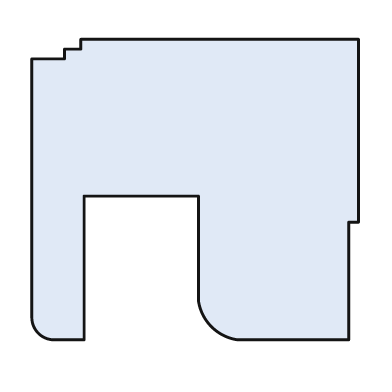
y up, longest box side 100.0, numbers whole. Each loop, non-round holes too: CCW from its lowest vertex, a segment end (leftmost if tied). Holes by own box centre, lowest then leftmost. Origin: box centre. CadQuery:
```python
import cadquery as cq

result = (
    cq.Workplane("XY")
    .moveTo(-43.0, -46.0)
    .lineTo(-34.0, -46.0)
    .lineTo(-34.0, -2.0)
    .lineTo(1.0, -2.0)
    .lineTo(1.0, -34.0)
    .threePointArc((5.0, -42.0), (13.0, -46.0))
    .lineTo(47.0, -46.0)
    .lineTo(47.0, -10.0)
    .lineTo(50.0, -10.0)
    .lineTo(50.0, 46.0)
    .lineTo(-35.0, 46.0)
    .lineTo(-35.0, 43.0)
    .lineTo(-40.0, 43.0)
    .lineTo(-40.0, 40.0)
    .lineTo(-50.0, 40.0)
    .lineTo(-50.0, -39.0)
    .threePointArc((-48.0, -44.0), (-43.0, -46.0))
    .close()
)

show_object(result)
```